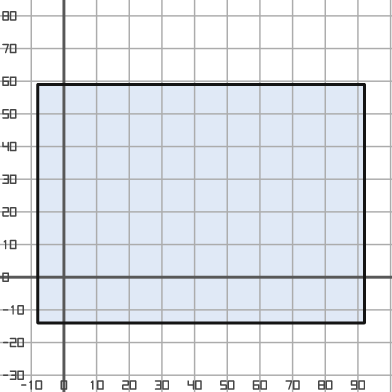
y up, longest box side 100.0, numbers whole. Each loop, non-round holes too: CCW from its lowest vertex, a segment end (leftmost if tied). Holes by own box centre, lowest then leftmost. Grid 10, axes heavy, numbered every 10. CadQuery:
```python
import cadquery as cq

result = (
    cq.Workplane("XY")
    .moveTo(-8.0, -14.0)
    .lineTo(92.0, -14.0)
    .lineTo(92.0, 59.0)
    .lineTo(-8.0, 59.0)
    .close()
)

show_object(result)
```